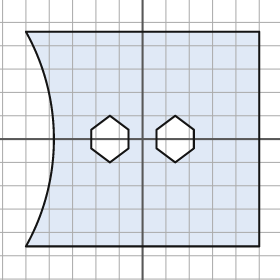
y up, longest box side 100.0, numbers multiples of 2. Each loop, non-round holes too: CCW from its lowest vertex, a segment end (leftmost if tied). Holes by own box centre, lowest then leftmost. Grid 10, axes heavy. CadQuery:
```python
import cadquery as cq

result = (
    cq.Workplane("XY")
    .moveTo(-50.0, -46.0)
    .lineTo(50.0, -46.0)
    .lineTo(50.0, 46.0)
    .lineTo(-50.0, 46.0)
    .threePointArc((-38.0, 0.0), (-50.0, -46.0))
    .close()
    .moveTo(-14.0, -10.0)
    .lineTo(-6.0, -4.0)
    .lineTo(-6.0, 4.0)
    .lineTo(-14.0, 10.0)
    .lineTo(-22.0, 4.0)
    .lineTo(-22.0, -4.0)
    .close()
    .moveTo(14.0, -10.0)
    .lineTo(22.0, -4.0)
    .lineTo(22.0, 4.0)
    .lineTo(14.0, 10.0)
    .lineTo(6.0, 4.0)
    .lineTo(6.0, -4.0)
    .close()
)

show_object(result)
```